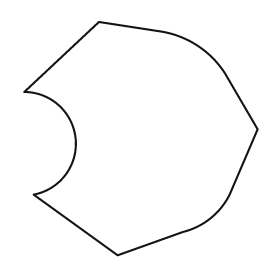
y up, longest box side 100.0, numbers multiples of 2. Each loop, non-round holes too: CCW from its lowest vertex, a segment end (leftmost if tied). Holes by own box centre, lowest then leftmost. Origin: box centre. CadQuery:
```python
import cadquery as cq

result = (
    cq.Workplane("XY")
    .moveTo(-10.0, -50.0)
    .lineTo(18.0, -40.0)
    .threePointArc((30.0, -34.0), (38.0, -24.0))
    .lineTo(50.0, 4.0)
    .lineTo(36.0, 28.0)
    .threePointArc((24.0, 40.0), (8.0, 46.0))
    .lineTo(-18.0, 50.0)
    .lineTo(-50.0, 20.0)
    .threePointArc((-28.0, 0.0), (-46.0, -24.0))
    .close()
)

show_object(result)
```